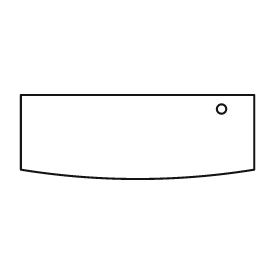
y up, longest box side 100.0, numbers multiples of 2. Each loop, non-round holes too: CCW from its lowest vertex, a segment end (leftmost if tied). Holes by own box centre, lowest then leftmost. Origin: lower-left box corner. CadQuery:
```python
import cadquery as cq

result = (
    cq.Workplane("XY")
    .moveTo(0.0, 4.0)
    .threePointArc((50.0, 0.0), (100.0, 4.0))
    .lineTo(100.0, 36.0)
    .lineTo(0.0, 36.0)
    .close()
    .moveTo(86.0, 30.0)
    .circle(2.0)
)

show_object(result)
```